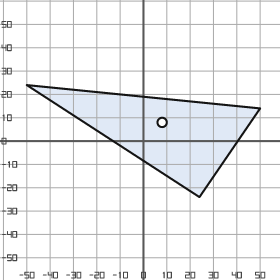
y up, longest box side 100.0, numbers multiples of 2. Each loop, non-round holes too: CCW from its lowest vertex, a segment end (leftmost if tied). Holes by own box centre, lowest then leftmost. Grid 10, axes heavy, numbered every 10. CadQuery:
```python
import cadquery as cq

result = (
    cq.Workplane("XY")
    .moveTo(24.0, -24.0)
    .lineTo(50.0, 14.0)
    .lineTo(-50.0, 24.0)
    .close()
    .moveTo(8.0, 8.0)
    .circle(2.0)
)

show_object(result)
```